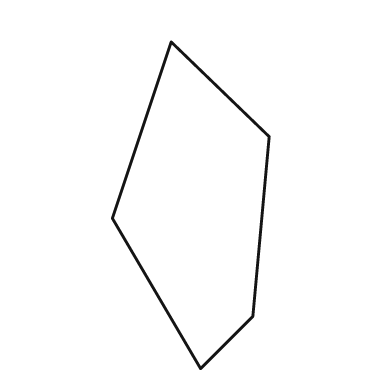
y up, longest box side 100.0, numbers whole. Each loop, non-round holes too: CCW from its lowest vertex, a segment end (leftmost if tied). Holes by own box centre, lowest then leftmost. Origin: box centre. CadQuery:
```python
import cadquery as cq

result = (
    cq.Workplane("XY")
    .moveTo(3.0, -50.0)
    .lineTo(19.0, -34.0)
    .lineTo(24.0, 21.0)
    .lineTo(-6.0, 50.0)
    .lineTo(-24.0, -4.0)
    .close()
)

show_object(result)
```